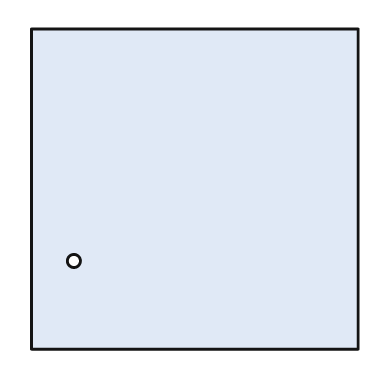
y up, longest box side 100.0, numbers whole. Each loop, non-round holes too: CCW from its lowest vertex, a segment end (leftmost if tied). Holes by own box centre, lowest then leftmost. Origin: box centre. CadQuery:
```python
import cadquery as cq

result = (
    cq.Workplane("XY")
    .moveTo(-50.0, -49.0)
    .lineTo(50.0, -49.0)
    .lineTo(50.0, 49.0)
    .lineTo(-50.0, 49.0)
    .close()
    .moveTo(-37.0, -22.0)
    .circle(2.0)
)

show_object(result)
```